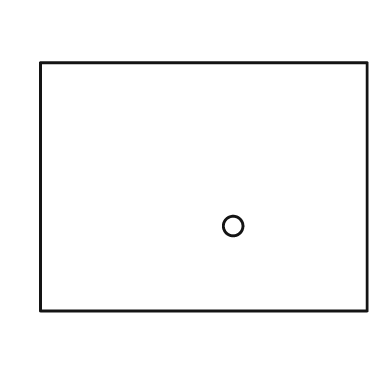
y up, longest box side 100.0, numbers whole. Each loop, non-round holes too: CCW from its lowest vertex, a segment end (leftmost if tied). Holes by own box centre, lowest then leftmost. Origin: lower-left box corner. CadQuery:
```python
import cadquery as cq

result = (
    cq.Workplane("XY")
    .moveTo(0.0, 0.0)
    .lineTo(100.0, 0.0)
    .lineTo(100.0, 76.0)
    .lineTo(0.0, 76.0)
    .close()
    .moveTo(59.0, 26.0)
    .circle(3.0)
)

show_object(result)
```